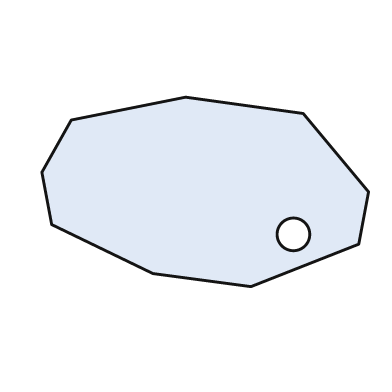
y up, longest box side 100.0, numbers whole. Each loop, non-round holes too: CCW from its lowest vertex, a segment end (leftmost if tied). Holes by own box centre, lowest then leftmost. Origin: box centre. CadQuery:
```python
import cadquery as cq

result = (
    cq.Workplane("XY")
    .moveTo(14.0, -29.0)
    .lineTo(47.0, -16.0)
    .lineTo(50.0, 0.0)
    .lineTo(30.0, 24.0)
    .lineTo(-6.0, 29.0)
    .lineTo(-41.0, 22.0)
    .lineTo(-50.0, 6.0)
    .lineTo(-47.0, -10.0)
    .lineTo(-16.0, -25.0)
    .close()
    .moveTo(27.0, -13.0)
    .circle(5.0)
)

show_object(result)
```